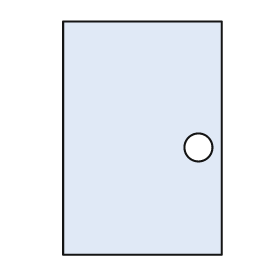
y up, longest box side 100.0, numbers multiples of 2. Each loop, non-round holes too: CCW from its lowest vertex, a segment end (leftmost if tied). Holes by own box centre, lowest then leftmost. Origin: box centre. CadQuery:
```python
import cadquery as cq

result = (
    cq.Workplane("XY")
    .moveTo(-34.0, -50.0)
    .lineTo(34.0, -50.0)
    .lineTo(34.0, 50.0)
    .lineTo(-34.0, 50.0)
    .close()
    .moveTo(24.0, -4.0)
    .circle(6.0)
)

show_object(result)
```